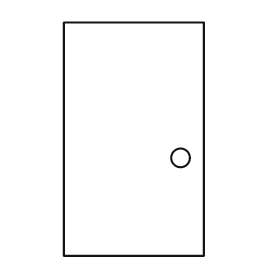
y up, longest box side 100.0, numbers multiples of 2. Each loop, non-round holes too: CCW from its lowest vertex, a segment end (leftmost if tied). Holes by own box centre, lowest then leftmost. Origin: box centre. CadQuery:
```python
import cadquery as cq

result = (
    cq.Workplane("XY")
    .moveTo(-30.0, -50.0)
    .lineTo(30.0, -50.0)
    .lineTo(30.0, 50.0)
    .lineTo(-30.0, 50.0)
    .close()
    .moveTo(20.0, -8.0)
    .circle(4.0)
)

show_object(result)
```